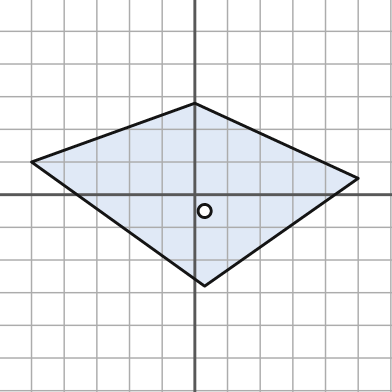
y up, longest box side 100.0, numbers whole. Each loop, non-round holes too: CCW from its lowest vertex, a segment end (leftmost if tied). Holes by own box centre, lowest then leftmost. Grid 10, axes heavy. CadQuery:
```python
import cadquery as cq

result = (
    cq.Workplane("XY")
    .moveTo(3.0, -28.0)
    .lineTo(50.0, 5.0)
    .lineTo(0.0, 28.0)
    .lineTo(-50.0, 10.0)
    .close()
    .moveTo(3.0, -5.0)
    .circle(2.0)
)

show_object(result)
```